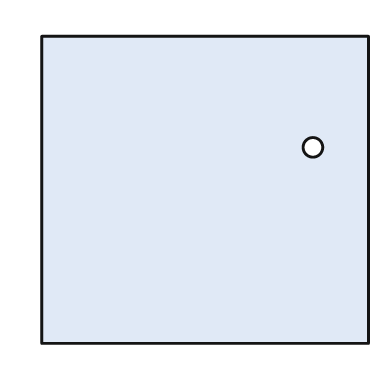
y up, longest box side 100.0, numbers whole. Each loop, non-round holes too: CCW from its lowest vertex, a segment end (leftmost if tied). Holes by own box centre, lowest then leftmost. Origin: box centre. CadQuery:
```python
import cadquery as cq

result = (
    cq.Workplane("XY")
    .moveTo(-50.0, -47.0)
    .lineTo(50.0, -47.0)
    .lineTo(50.0, 47.0)
    .lineTo(-50.0, 47.0)
    .close()
    .moveTo(33.0, 13.0)
    .circle(3.0)
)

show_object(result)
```